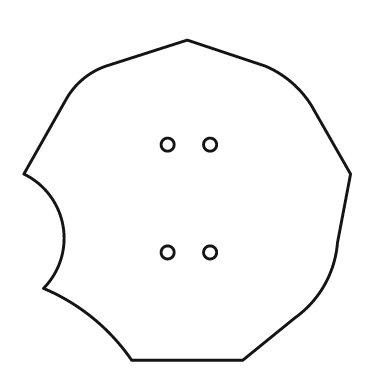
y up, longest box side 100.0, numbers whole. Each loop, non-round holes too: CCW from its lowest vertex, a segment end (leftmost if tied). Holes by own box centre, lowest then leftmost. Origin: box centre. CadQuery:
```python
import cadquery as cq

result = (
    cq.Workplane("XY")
    .moveTo(-17.0, -49.0)
    .lineTo(17.0, -49.0)
    .lineTo(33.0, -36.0)
    .threePointArc((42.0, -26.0), (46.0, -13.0))
    .lineTo(50.0, 8.0)
    .lineTo(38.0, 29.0)
    .threePointArc((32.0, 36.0), (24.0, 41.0))
    .lineTo(0.0, 49.0)
    .lineTo(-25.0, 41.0)
    .threePointArc((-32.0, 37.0), (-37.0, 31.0))
    .lineTo(-50.0, 8.0)
    .threePointArc((-38.0, -8.0), (-44.0, -27.0))
    .threePointArc((-29.0, -36.0), (-17.0, -49.0))
    .close()
    .moveTo(-6.0, -16.0)
    .circle(2.0)
    .moveTo(7.0, -16.0)
    .circle(2.0)
    .moveTo(-6.0, 17.0)
    .circle(2.0)
    .moveTo(7.0, 17.0)
    .circle(2.0)
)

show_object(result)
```